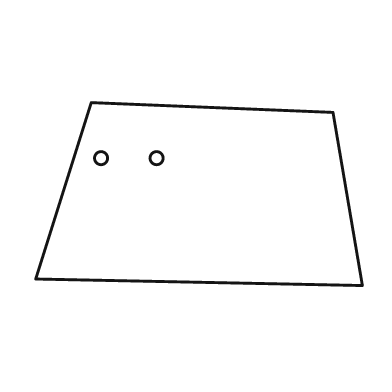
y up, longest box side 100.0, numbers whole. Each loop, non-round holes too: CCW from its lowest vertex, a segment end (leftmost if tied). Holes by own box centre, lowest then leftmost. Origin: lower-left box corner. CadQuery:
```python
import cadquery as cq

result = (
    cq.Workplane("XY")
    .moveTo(100.0, 0.0)
    .lineTo(91.0, 53.0)
    .lineTo(17.0, 56.0)
    .lineTo(0.0, 2.0)
    .close()
    .moveTo(20.0, 39.0)
    .circle(2.0)
    .moveTo(37.0, 39.0)
    .circle(2.0)
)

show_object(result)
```